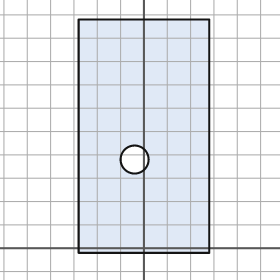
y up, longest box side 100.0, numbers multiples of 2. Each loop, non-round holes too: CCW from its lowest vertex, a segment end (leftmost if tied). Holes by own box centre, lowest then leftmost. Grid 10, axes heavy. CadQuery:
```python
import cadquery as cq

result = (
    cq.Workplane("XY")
    .moveTo(-28.0, -2.0)
    .lineTo(28.0, -2.0)
    .lineTo(28.0, 98.0)
    .lineTo(-28.0, 98.0)
    .close()
    .moveTo(-4.0, 38.0)
    .circle(6.0)
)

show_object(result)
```